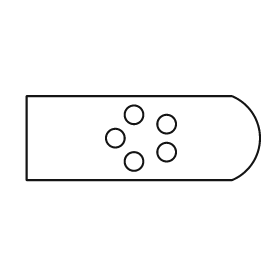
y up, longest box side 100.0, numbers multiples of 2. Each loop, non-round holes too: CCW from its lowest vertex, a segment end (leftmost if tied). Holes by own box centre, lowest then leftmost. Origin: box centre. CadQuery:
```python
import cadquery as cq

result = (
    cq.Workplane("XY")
    .moveTo(-50.0, -18.0)
    .lineTo(38.0, -18.0)
    .threePointArc((50.0, 0.0), (38.0, 18.0))
    .lineTo(-50.0, 18.0)
    .close()
    .moveTo(-4.0, -10.0)
    .circle(4.0)
    .moveTo(10.0, -6.0)
    .circle(4.0)
    .moveTo(-12.0, 0.0)
    .circle(4.0)
    .moveTo(10.0, 6.0)
    .circle(4.0)
    .moveTo(-4.0, 10.0)
    .circle(4.0)
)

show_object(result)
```